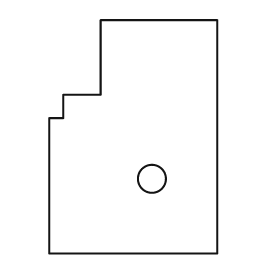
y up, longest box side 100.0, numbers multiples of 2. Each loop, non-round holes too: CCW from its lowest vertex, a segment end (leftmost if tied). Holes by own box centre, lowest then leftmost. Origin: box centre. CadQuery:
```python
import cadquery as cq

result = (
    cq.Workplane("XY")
    .moveTo(-36.0, -50.0)
    .lineTo(36.0, -50.0)
    .lineTo(36.0, 50.0)
    .lineTo(-14.0, 50.0)
    .lineTo(-14.0, 18.0)
    .lineTo(-30.0, 18.0)
    .lineTo(-30.0, 8.0)
    .lineTo(-36.0, 8.0)
    .close()
    .moveTo(8.0, -18.0)
    .circle(6.0)
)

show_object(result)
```